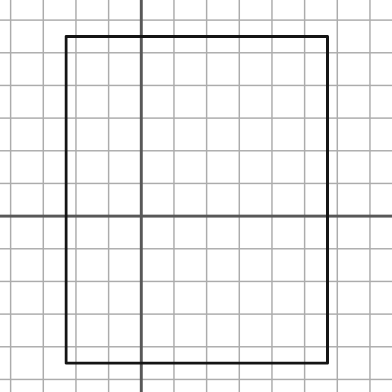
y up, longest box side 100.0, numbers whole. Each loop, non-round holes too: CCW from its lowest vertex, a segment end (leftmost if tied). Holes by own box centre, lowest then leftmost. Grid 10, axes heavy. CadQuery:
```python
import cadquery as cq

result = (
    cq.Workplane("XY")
    .moveTo(-23.0, -45.0)
    .lineTo(57.0, -45.0)
    .lineTo(57.0, 55.0)
    .lineTo(-23.0, 55.0)
    .close()
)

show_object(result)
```